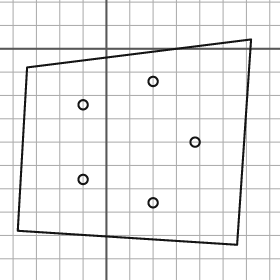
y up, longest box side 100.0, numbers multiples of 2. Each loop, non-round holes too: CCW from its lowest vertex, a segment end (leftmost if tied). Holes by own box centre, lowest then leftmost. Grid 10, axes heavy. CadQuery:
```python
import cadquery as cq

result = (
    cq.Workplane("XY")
    .moveTo(56.0, -84.0)
    .lineTo(62.0, 4.0)
    .lineTo(-34.0, -8.0)
    .lineTo(-38.0, -78.0)
    .close()
    .moveTo(20.0, -66.0)
    .circle(2.0)
    .moveTo(-10.0, -56.0)
    .circle(2.0)
    .moveTo(38.0, -40.0)
    .circle(2.0)
    .moveTo(-10.0, -24.0)
    .circle(2.0)
    .moveTo(20.0, -14.0)
    .circle(2.0)
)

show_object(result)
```